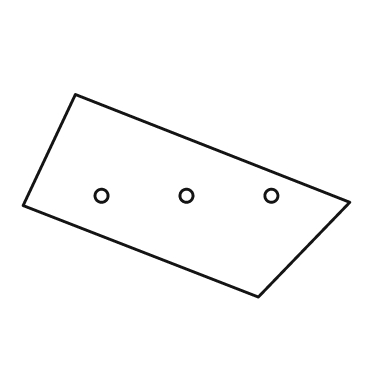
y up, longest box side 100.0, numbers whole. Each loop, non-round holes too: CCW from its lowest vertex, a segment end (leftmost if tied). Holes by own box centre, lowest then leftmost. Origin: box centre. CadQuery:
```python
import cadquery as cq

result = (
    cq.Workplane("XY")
    .moveTo(22.0, -31.0)
    .lineTo(50.0, -2.0)
    .lineTo(-34.0, 31.0)
    .lineTo(-50.0, -3.0)
    .close()
    .moveTo(-26.0, 0.0)
    .circle(2.0)
    .moveTo(0.0, 0.0)
    .circle(2.0)
    .moveTo(26.0, 0.0)
    .circle(2.0)
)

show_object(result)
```